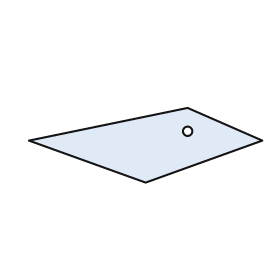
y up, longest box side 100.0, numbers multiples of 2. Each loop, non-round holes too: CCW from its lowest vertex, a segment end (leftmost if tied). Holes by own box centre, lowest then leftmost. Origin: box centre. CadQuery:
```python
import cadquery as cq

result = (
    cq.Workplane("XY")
    .moveTo(0.0, -16.0)
    .lineTo(50.0, 2.0)
    .lineTo(18.0, 16.0)
    .lineTo(-50.0, 2.0)
    .close()
    .moveTo(18.0, 6.0)
    .circle(2.0)
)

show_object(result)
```